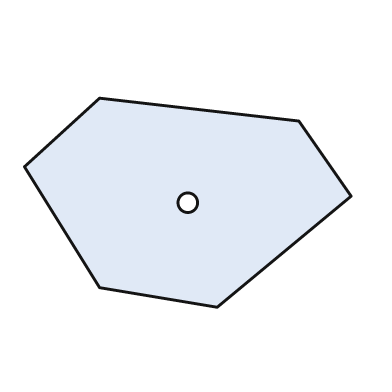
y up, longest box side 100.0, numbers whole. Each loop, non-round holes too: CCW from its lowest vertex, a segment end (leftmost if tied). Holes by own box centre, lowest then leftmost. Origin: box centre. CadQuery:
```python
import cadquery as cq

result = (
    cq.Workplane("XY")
    .moveTo(9.0, -32.0)
    .lineTo(50.0, 2.0)
    .lineTo(34.0, 25.0)
    .lineTo(-27.0, 32.0)
    .lineTo(-50.0, 11.0)
    .lineTo(-27.0, -26.0)
    .close()
    .moveTo(0.0, 0.0)
    .circle(3.0)
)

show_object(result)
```